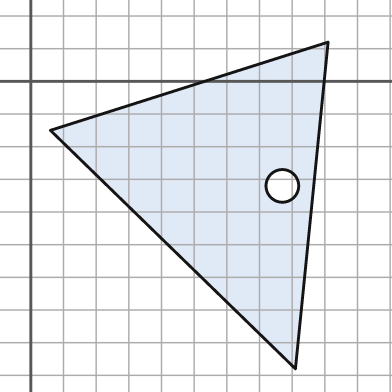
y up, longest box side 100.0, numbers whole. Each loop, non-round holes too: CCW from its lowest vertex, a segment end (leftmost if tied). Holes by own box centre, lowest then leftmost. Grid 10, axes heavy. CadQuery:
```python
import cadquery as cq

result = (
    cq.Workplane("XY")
    .moveTo(81.0, -88.0)
    .lineTo(91.0, 12.0)
    .lineTo(6.0, -15.0)
    .close()
    .moveTo(77.0, -32.0)
    .circle(5.0)
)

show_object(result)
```